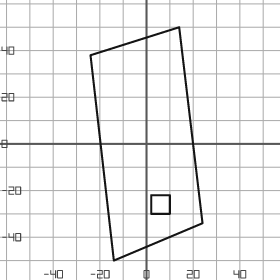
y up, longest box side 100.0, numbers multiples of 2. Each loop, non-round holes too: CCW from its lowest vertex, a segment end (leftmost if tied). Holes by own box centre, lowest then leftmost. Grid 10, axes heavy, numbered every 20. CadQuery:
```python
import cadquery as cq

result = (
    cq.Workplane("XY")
    .moveTo(-14.0, -50.0)
    .lineTo(24.0, -34.0)
    .lineTo(14.0, 50.0)
    .lineTo(-24.0, 38.0)
    .close()
    .moveTo(2.0, -30.0)
    .lineTo(10.0, -30.0)
    .lineTo(10.0, -22.0)
    .lineTo(2.0, -22.0)
    .close()
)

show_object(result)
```